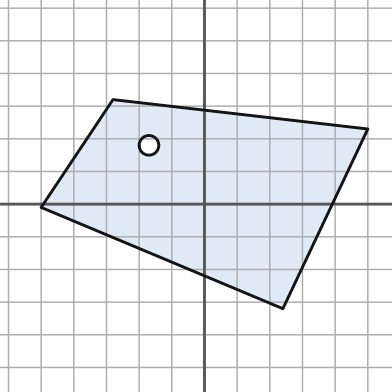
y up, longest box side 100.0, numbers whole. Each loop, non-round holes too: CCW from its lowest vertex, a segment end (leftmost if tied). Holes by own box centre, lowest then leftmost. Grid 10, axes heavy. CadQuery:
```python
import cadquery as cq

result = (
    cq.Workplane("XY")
    .moveTo(24.0, -32.0)
    .lineTo(50.0, 23.0)
    .lineTo(-28.0, 32.0)
    .lineTo(-50.0, -1.0)
    .close()
    .moveTo(-17.0, 18.0)
    .circle(3.0)
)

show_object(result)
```